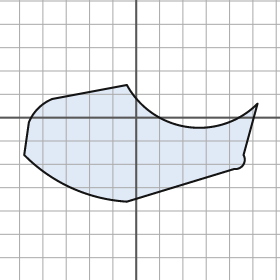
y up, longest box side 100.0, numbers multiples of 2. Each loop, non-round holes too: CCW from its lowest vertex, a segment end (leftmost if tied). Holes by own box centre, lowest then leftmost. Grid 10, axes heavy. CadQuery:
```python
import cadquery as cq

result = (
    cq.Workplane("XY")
    .moveTo(-4.0, -36.0)
    .lineTo(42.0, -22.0)
    .threePointArc((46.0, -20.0), (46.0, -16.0))
    .lineTo(52.0, 6.0)
    .threePointArc((22.0, -4.0), (-4.0, 14.0))
    .lineTo(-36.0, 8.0)
    .threePointArc((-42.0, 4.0), (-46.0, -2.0))
    .lineTo(-48.0, -16.0)
    .threePointArc((-28.0, -30.0), (-4.0, -36.0))
    .close()
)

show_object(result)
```